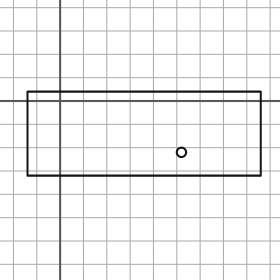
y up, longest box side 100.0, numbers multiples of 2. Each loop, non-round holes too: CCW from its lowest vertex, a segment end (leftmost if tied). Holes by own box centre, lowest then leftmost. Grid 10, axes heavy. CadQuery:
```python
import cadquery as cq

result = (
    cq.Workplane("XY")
    .moveTo(-14.0, -32.0)
    .lineTo(86.0, -32.0)
    .lineTo(86.0, 4.0)
    .lineTo(-14.0, 4.0)
    .close()
    .moveTo(52.0, -22.0)
    .circle(2.0)
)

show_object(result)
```